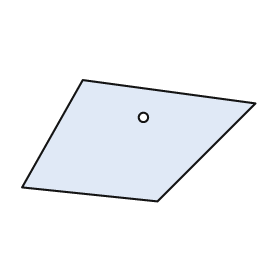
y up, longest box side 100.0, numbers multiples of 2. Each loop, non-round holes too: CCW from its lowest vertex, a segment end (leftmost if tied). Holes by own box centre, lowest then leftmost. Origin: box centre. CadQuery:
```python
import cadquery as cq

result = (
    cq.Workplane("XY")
    .moveTo(8.0, -26.0)
    .lineTo(50.0, 16.0)
    .lineTo(-24.0, 26.0)
    .lineTo(-50.0, -20.0)
    .close()
    .moveTo(2.0, 10.0)
    .circle(2.0)
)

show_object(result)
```